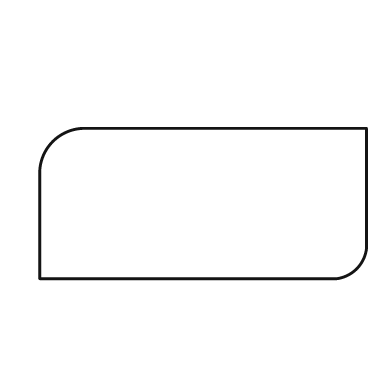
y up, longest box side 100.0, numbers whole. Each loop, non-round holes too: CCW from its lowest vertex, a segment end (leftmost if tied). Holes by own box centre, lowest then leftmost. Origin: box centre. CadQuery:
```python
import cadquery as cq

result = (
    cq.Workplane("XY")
    .moveTo(-50.0, -23.0)
    .lineTo(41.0, -23.0)
    .threePointArc((47.0, -20.0), (50.0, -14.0))
    .lineTo(50.0, 23.0)
    .lineTo(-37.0, 23.0)
    .threePointArc((-46.0, 19.0), (-50.0, 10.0))
    .close()
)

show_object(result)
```